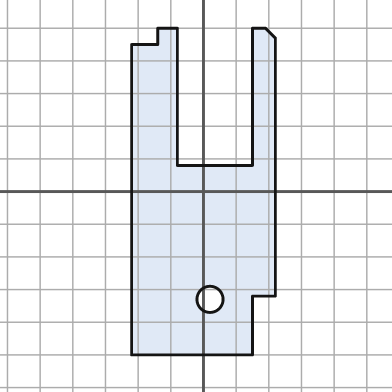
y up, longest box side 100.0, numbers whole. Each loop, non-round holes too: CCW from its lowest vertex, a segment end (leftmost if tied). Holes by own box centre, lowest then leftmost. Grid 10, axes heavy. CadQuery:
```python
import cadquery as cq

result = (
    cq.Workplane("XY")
    .moveTo(-22.0, -50.0)
    .lineTo(15.0, -50.0)
    .lineTo(15.0, -32.0)
    .lineTo(22.0, -32.0)
    .lineTo(22.0, 47.0)
    .lineTo(19.0, 50.0)
    .lineTo(15.0, 50.0)
    .lineTo(15.0, 8.0)
    .lineTo(-8.0, 8.0)
    .lineTo(-8.0, 50.0)
    .lineTo(-14.0, 50.0)
    .lineTo(-14.0, 45.0)
    .lineTo(-22.0, 45.0)
    .close()
    .moveTo(2.0, -33.0)
    .circle(4.0)
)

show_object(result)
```